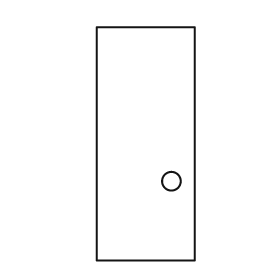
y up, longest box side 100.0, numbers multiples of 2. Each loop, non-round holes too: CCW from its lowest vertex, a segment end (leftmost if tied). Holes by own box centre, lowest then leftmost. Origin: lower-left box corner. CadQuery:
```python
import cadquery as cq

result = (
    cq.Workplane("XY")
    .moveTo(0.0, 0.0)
    .lineTo(42.0, 0.0)
    .lineTo(42.0, 100.0)
    .lineTo(0.0, 100.0)
    .close()
    .moveTo(32.0, 34.0)
    .circle(4.0)
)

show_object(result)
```